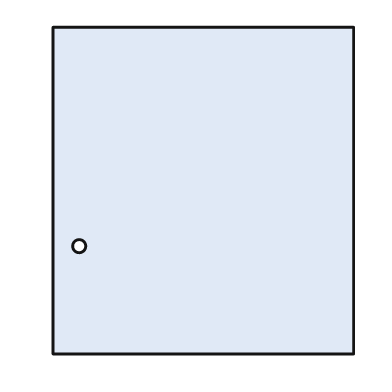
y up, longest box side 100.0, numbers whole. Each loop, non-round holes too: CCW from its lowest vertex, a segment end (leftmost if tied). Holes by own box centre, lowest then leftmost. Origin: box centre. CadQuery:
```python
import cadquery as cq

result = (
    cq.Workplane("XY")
    .moveTo(-46.0, -50.0)
    .lineTo(46.0, -50.0)
    .lineTo(46.0, 50.0)
    .lineTo(-46.0, 50.0)
    .close()
    .moveTo(-38.0, -17.0)
    .circle(2.0)
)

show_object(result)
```